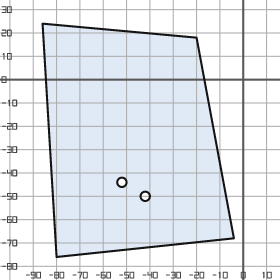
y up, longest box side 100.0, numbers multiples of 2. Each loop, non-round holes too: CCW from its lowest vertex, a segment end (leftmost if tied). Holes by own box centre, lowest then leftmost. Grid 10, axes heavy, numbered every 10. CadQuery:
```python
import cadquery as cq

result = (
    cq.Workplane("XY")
    .moveTo(-80.0, -76.0)
    .lineTo(-4.0, -68.0)
    .lineTo(-20.0, 18.0)
    .lineTo(-86.0, 24.0)
    .close()
    .moveTo(-42.0, -50.0)
    .circle(2.0)
    .moveTo(-52.0, -44.0)
    .circle(2.0)
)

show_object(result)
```